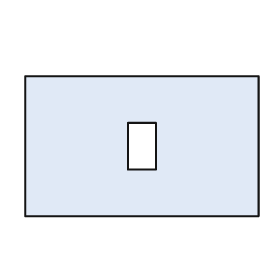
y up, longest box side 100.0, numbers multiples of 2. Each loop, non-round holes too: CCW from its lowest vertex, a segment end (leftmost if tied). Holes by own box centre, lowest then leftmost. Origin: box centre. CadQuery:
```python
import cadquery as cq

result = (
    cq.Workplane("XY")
    .moveTo(-50.0, -30.0)
    .lineTo(50.0, -30.0)
    .lineTo(50.0, 30.0)
    .lineTo(-50.0, 30.0)
    .close()
    .moveTo(-6.0, -10.0)
    .lineTo(6.0, -10.0)
    .lineTo(6.0, 10.0)
    .lineTo(-6.0, 10.0)
    .close()
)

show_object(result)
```